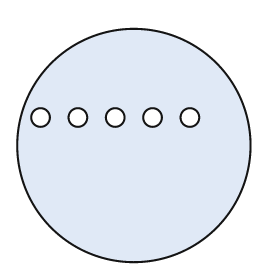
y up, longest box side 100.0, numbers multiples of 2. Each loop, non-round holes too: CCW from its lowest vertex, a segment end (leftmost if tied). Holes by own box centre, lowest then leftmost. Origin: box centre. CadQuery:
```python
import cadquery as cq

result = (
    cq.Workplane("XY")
    .moveTo(0.0, 0.0)
    .circle(50.0)
    .moveTo(-40.0, 12.0)
    .circle(4.0)
    .moveTo(-24.0, 12.0)
    .circle(4.0)
    .moveTo(-8.0, 12.0)
    .circle(4.0)
    .moveTo(8.0, 12.0)
    .circle(4.0)
    .moveTo(24.0, 12.0)
    .circle(4.0)
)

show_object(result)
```